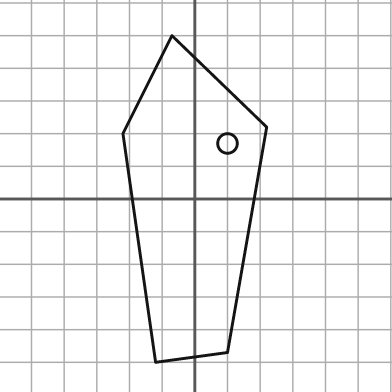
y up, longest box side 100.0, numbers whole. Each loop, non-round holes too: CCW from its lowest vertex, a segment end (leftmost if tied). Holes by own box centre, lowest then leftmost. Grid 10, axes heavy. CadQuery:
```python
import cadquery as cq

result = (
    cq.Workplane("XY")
    .moveTo(-12.0, -50.0)
    .lineTo(10.0, -47.0)
    .lineTo(22.0, 22.0)
    .lineTo(-7.0, 50.0)
    .lineTo(-22.0, 20.0)
    .close()
    .moveTo(10.0, 17.0)
    .circle(3.0)
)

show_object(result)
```